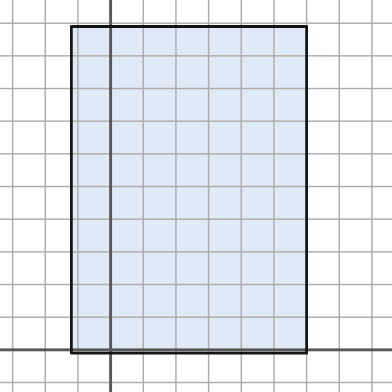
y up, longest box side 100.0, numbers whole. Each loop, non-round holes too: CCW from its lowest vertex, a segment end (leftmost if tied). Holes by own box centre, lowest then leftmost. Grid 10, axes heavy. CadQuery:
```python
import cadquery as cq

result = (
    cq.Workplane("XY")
    .moveTo(-12.0, -1.0)
    .lineTo(60.0, -1.0)
    .lineTo(60.0, 99.0)
    .lineTo(-12.0, 99.0)
    .close()
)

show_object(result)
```